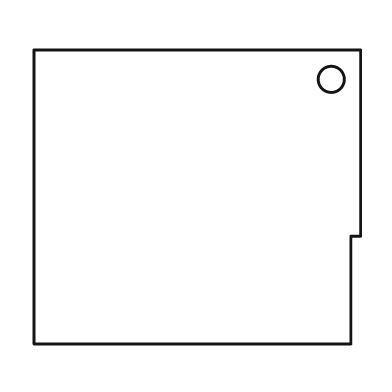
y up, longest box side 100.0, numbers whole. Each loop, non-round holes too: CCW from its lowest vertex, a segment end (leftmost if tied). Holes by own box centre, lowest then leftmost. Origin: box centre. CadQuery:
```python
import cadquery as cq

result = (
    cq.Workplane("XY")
    .moveTo(-50.0, -45.0)
    .lineTo(47.0, -45.0)
    .lineTo(47.0, -12.0)
    .lineTo(50.0, -12.0)
    .lineTo(50.0, 45.0)
    .lineTo(-50.0, 45.0)
    .close()
    .moveTo(41.0, 36.0)
    .circle(4.0)
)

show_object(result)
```